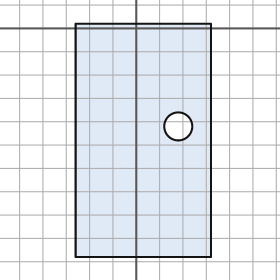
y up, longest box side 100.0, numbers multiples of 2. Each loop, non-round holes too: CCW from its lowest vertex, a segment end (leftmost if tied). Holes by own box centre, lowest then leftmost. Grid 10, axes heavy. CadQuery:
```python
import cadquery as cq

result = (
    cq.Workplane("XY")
    .moveTo(-26.0, -98.0)
    .lineTo(32.0, -98.0)
    .lineTo(32.0, 2.0)
    .lineTo(-26.0, 2.0)
    .close()
    .moveTo(18.0, -42.0)
    .circle(6.0)
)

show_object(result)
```